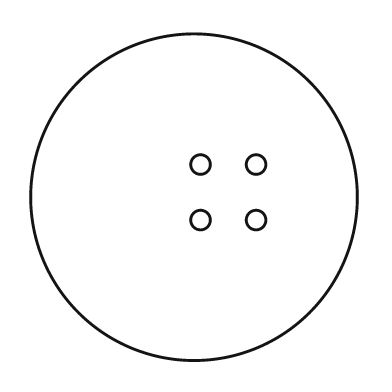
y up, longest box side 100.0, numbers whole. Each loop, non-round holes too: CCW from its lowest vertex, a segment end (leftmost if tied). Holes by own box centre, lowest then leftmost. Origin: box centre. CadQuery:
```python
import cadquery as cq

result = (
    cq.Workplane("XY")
    .moveTo(0.0, 0.0)
    .circle(50.0)
    .moveTo(2.0, -7.0)
    .circle(3.0)
    .moveTo(19.0, -7.0)
    .circle(3.0)
    .moveTo(2.0, 10.0)
    .circle(3.0)
    .moveTo(19.0, 10.0)
    .circle(3.0)
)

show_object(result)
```